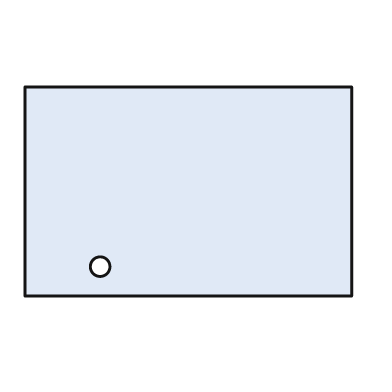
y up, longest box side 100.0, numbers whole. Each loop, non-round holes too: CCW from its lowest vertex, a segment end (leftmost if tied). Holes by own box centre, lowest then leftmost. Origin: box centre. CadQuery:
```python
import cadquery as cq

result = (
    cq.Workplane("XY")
    .moveTo(-50.0, -32.0)
    .lineTo(50.0, -32.0)
    .lineTo(50.0, 32.0)
    .lineTo(-50.0, 32.0)
    .close()
    .moveTo(-27.0, -23.0)
    .circle(3.0)
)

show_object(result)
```